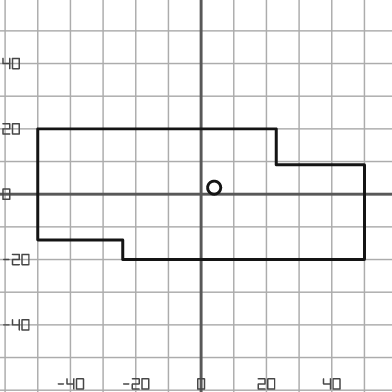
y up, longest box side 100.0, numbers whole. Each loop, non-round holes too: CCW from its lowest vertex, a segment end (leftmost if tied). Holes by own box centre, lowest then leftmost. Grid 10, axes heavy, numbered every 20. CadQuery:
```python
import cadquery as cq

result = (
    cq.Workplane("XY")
    .moveTo(-24.0, -20.0)
    .lineTo(50.0, -20.0)
    .lineTo(50.0, 9.0)
    .lineTo(23.0, 9.0)
    .lineTo(23.0, 20.0)
    .lineTo(-50.0, 20.0)
    .lineTo(-50.0, -14.0)
    .lineTo(-24.0, -14.0)
    .close()
    .moveTo(4.0, 2.0)
    .circle(2.0)
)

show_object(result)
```